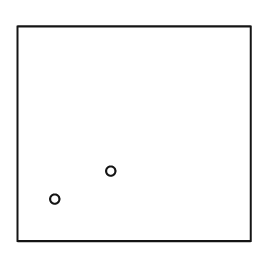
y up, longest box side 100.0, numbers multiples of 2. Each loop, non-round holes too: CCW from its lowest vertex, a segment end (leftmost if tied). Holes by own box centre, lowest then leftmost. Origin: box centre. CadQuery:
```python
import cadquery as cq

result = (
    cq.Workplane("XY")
    .moveTo(-50.0, -46.0)
    .lineTo(50.0, -46.0)
    .lineTo(50.0, 46.0)
    .lineTo(-50.0, 46.0)
    .close()
    .moveTo(-34.0, -28.0)
    .circle(2.0)
    .moveTo(-10.0, -16.0)
    .circle(2.0)
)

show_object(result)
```